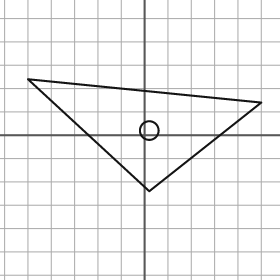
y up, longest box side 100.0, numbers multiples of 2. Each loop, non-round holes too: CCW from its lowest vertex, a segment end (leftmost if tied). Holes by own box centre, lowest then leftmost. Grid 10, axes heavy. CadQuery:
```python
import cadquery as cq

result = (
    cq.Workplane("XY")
    .moveTo(2.0, -24.0)
    .lineTo(50.0, 14.0)
    .lineTo(-50.0, 24.0)
    .close()
    .moveTo(2.0, 2.0)
    .circle(4.0)
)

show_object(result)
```